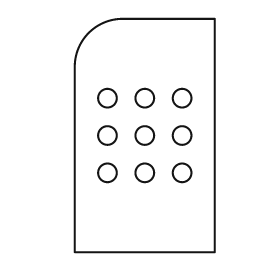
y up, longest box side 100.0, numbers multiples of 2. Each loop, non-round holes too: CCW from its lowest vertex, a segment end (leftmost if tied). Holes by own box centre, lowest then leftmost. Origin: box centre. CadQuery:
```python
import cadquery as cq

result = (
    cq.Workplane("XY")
    .moveTo(-30.0, -50.0)
    .lineTo(30.0, -50.0)
    .lineTo(30.0, 50.0)
    .lineTo(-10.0, 50.0)
    .threePointArc((-24.0, 44.0), (-30.0, 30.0))
    .close()
    .moveTo(-16.0, -16.0)
    .circle(4.0)
    .moveTo(0.0, -16.0)
    .circle(4.0)
    .moveTo(16.0, -16.0)
    .circle(4.0)
    .moveTo(-16.0, 0.0)
    .circle(4.0)
    .moveTo(0.0, 0.0)
    .circle(4.0)
    .moveTo(16.0, 0.0)
    .circle(4.0)
    .moveTo(-16.0, 16.0)
    .circle(4.0)
    .moveTo(0.0, 16.0)
    .circle(4.0)
    .moveTo(16.0, 16.0)
    .circle(4.0)
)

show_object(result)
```